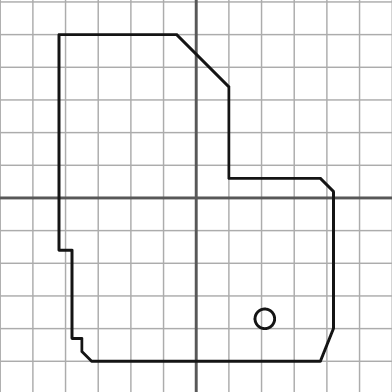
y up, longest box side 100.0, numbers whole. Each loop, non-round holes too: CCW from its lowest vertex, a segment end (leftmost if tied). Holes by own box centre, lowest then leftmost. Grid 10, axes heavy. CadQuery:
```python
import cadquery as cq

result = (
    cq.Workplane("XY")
    .moveTo(-32.0, -50.0)
    .lineTo(38.0, -50.0)
    .lineTo(42.0, -40.0)
    .lineTo(42.0, 2.0)
    .lineTo(38.0, 6.0)
    .lineTo(10.0, 6.0)
    .lineTo(10.0, 34.0)
    .lineTo(-6.0, 50.0)
    .lineTo(-42.0, 50.0)
    .lineTo(-42.0, -16.0)
    .lineTo(-38.0, -16.0)
    .lineTo(-38.0, -43.0)
    .lineTo(-35.0, -43.0)
    .lineTo(-35.0, -47.0)
    .close()
    .moveTo(21.0, -37.0)
    .circle(3.0)
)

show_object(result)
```